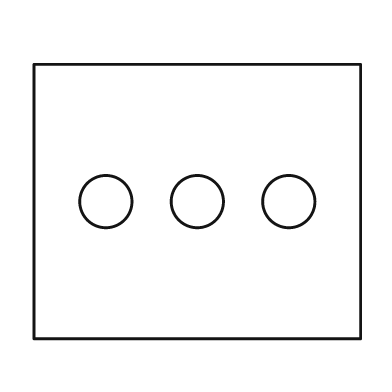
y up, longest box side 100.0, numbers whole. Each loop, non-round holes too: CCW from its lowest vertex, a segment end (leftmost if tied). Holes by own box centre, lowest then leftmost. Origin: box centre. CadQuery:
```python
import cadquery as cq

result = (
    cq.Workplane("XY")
    .moveTo(-50.0, -42.0)
    .lineTo(50.0, -42.0)
    .lineTo(50.0, 42.0)
    .lineTo(-50.0, 42.0)
    .close()
    .moveTo(-28.0, 0.0)
    .circle(8.0)
    .moveTo(0.0, 0.0)
    .circle(8.0)
    .moveTo(28.0, 0.0)
    .circle(8.0)
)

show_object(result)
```